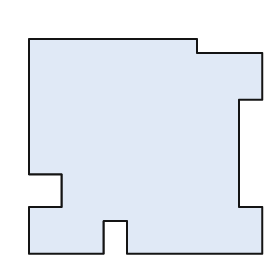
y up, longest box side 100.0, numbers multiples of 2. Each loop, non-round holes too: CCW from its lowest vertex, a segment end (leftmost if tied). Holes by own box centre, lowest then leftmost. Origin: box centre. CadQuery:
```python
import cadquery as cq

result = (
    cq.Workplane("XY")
    .moveTo(-50.0, -46.0)
    .lineTo(-18.0, -46.0)
    .lineTo(-18.0, -32.0)
    .lineTo(-8.0, -32.0)
    .lineTo(-8.0, -46.0)
    .lineTo(50.0, -46.0)
    .lineTo(50.0, -26.0)
    .lineTo(40.0, -26.0)
    .lineTo(40.0, 20.0)
    .lineTo(50.0, 20.0)
    .lineTo(50.0, 40.0)
    .lineTo(22.0, 40.0)
    .lineTo(22.0, 46.0)
    .lineTo(-50.0, 46.0)
    .lineTo(-50.0, -12.0)
    .lineTo(-36.0, -12.0)
    .lineTo(-36.0, -26.0)
    .lineTo(-50.0, -26.0)
    .close()
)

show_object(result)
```